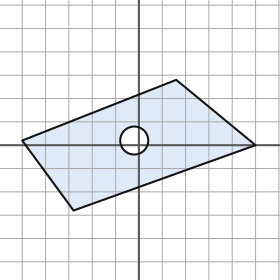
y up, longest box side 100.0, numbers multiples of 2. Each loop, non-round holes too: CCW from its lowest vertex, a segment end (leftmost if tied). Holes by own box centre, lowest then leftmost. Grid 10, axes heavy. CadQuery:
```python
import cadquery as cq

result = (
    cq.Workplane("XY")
    .moveTo(-28.0, -28.0)
    .lineTo(50.0, 0.0)
    .lineTo(16.0, 28.0)
    .lineTo(-50.0, 2.0)
    .close()
    .moveTo(-2.0, 2.0)
    .circle(6.0)
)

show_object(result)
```